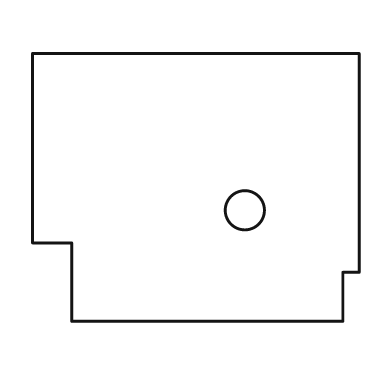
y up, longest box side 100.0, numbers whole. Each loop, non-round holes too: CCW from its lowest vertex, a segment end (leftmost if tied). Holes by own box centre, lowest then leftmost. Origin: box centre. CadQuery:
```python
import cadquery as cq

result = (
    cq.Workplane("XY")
    .moveTo(-38.0, -41.0)
    .lineTo(45.0, -41.0)
    .lineTo(45.0, -26.0)
    .lineTo(50.0, -26.0)
    .lineTo(50.0, 41.0)
    .lineTo(-50.0, 41.0)
    .lineTo(-50.0, -17.0)
    .lineTo(-38.0, -17.0)
    .close()
    .moveTo(15.0, -7.0)
    .circle(6.0)
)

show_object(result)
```